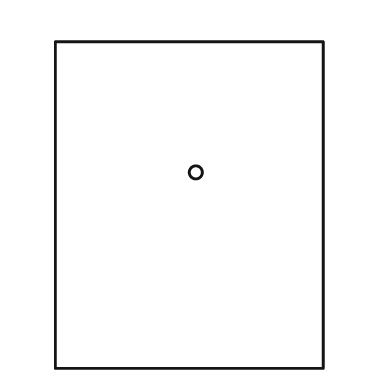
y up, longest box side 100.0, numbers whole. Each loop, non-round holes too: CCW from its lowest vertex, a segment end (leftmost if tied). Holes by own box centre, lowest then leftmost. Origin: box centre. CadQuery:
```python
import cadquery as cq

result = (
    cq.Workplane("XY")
    .moveTo(-41.0, -50.0)
    .lineTo(41.0, -50.0)
    .lineTo(41.0, 50.0)
    .lineTo(-41.0, 50.0)
    .close()
    .moveTo(2.0, 10.0)
    .circle(2.0)
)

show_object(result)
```